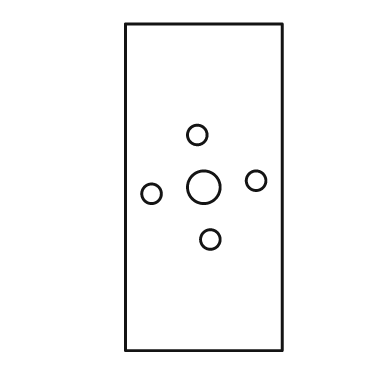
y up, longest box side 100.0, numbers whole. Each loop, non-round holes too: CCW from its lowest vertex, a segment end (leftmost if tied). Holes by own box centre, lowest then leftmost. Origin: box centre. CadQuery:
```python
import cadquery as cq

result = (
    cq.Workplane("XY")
    .moveTo(-24.0, -50.0)
    .lineTo(24.0, -50.0)
    .lineTo(24.0, 50.0)
    .lineTo(-24.0, 50.0)
    .close()
    .moveTo(2.0, -16.0)
    .circle(3.0)
    .moveTo(-16.0, -2.0)
    .circle(3.0)
    .moveTo(0.0, 0.0)
    .circle(5.0)
    .moveTo(16.0, 2.0)
    .circle(3.0)
    .moveTo(-2.0, 16.0)
    .circle(3.0)
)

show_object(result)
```